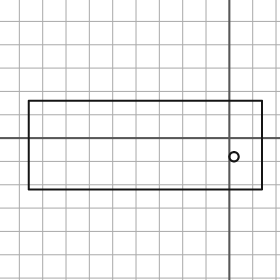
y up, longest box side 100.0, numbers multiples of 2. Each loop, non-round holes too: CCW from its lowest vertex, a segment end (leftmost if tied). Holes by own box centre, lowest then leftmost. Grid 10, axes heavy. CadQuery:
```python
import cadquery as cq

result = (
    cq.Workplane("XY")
    .moveTo(-86.0, -22.0)
    .lineTo(14.0, -22.0)
    .lineTo(14.0, 16.0)
    .lineTo(-86.0, 16.0)
    .close()
    .moveTo(2.0, -8.0)
    .circle(2.0)
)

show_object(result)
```